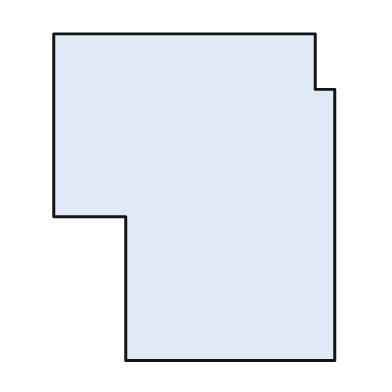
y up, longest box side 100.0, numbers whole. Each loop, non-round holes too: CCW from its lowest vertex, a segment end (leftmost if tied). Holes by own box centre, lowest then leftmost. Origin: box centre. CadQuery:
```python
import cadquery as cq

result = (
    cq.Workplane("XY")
    .moveTo(-21.0, -50.0)
    .lineTo(43.0, -50.0)
    .lineTo(43.0, 33.0)
    .lineTo(37.0, 33.0)
    .lineTo(37.0, 50.0)
    .lineTo(-43.0, 50.0)
    .lineTo(-43.0, -6.0)
    .lineTo(-21.0, -6.0)
    .close()
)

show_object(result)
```